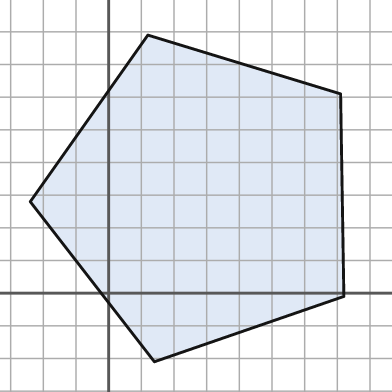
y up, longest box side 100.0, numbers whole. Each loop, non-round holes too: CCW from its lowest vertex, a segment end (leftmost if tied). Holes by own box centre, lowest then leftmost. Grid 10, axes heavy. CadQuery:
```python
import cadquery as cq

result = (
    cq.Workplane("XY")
    .moveTo(14.0, -21.0)
    .lineTo(72.0, -1.0)
    .lineTo(71.0, 61.0)
    .lineTo(12.0, 79.0)
    .lineTo(-24.0, 28.0)
    .close()
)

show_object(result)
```